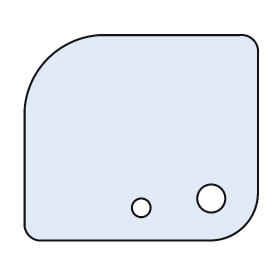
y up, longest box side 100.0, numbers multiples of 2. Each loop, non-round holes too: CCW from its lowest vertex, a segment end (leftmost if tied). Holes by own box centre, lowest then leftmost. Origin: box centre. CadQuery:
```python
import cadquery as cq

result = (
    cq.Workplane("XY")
    .moveTo(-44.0, -44.0)
    .lineTo(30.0, -44.0)
    .threePointArc((44.0, -38.0), (50.0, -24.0))
    .lineTo(50.0, 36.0)
    .threePointArc((48.0, 42.0), (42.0, 44.0))
    .lineTo(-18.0, 44.0)
    .threePointArc((-40.0, 34.0), (-50.0, 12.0))
    .lineTo(-50.0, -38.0)
    .threePointArc((-48.0, -42.0), (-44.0, -44.0))
    .close()
    .moveTo(0.0, -30.0)
    .circle(4.0)
    .moveTo(30.0, -26.0)
    .circle(6.0)
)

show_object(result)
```